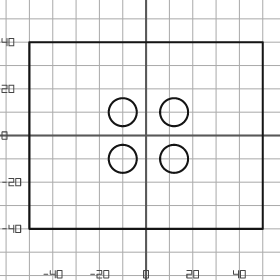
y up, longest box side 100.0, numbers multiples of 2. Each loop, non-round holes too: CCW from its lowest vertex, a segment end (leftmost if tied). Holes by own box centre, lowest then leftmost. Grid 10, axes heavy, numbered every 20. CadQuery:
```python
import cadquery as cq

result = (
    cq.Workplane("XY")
    .moveTo(-50.0, -40.0)
    .lineTo(50.0, -40.0)
    .lineTo(50.0, 40.0)
    .lineTo(-50.0, 40.0)
    .close()
    .moveTo(-10.0, -10.0)
    .circle(6.0)
    .moveTo(12.0, -10.0)
    .circle(6.0)
    .moveTo(-10.0, 10.0)
    .circle(6.0)
    .moveTo(12.0, 10.0)
    .circle(6.0)
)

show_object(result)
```